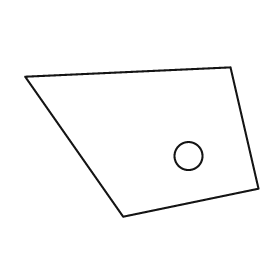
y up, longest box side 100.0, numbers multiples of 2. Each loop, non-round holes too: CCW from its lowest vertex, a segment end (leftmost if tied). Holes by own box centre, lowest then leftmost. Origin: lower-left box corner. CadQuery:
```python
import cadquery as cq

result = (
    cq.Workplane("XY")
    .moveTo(42.0, 0.0)
    .lineTo(100.0, 12.0)
    .lineTo(88.0, 64.0)
    .lineTo(0.0, 60.0)
    .close()
    .moveTo(70.0, 26.0)
    .circle(6.0)
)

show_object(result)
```